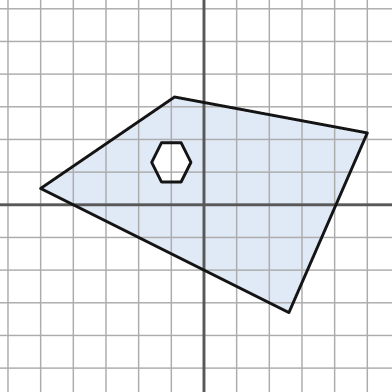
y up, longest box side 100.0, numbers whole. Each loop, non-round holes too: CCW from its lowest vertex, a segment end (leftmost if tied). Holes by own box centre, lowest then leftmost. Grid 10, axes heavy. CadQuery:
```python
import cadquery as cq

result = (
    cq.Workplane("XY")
    .moveTo(26.0, -33.0)
    .lineTo(50.0, 22.0)
    .lineTo(-9.0, 33.0)
    .lineTo(-50.0, 5.0)
    .close()
    .moveTo(-13.0, 7.0)
    .lineTo(-7.0, 7.0)
    .lineTo(-4.0, 13.0)
    .lineTo(-7.0, 19.0)
    .lineTo(-13.0, 19.0)
    .lineTo(-16.0, 13.0)
    .close()
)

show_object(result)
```